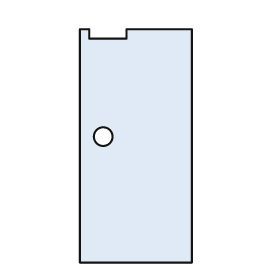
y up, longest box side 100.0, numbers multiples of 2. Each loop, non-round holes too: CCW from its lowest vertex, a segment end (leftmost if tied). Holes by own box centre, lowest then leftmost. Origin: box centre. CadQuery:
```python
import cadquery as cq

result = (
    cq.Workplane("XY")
    .moveTo(-24.0, -50.0)
    .lineTo(24.0, -50.0)
    .lineTo(24.0, 50.0)
    .lineTo(-4.0, 50.0)
    .lineTo(-4.0, 46.0)
    .lineTo(-20.0, 46.0)
    .lineTo(-20.0, 50.0)
    .lineTo(-24.0, 50.0)
    .close()
    .moveTo(-14.0, 4.0)
    .circle(4.0)
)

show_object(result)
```